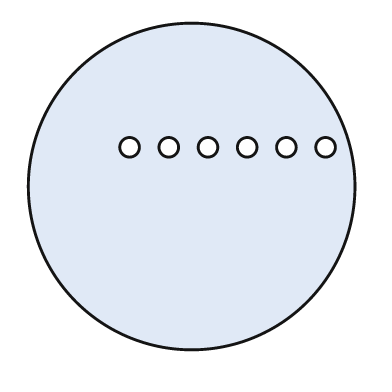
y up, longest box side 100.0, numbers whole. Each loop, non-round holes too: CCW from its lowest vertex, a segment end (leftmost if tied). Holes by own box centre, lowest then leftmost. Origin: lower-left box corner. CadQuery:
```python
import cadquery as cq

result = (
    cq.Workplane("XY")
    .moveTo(50.0, 50.0)
    .circle(50.0)
    .moveTo(31.0, 62.0)
    .circle(3.0)
    .moveTo(43.0, 62.0)
    .circle(3.0)
    .moveTo(55.0, 62.0)
    .circle(3.0)
    .moveTo(67.0, 62.0)
    .circle(3.0)
    .moveTo(79.0, 62.0)
    .circle(3.0)
    .moveTo(91.0, 62.0)
    .circle(3.0)
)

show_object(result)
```